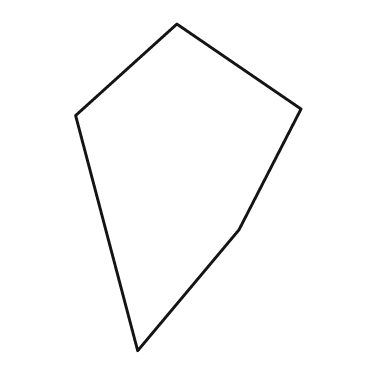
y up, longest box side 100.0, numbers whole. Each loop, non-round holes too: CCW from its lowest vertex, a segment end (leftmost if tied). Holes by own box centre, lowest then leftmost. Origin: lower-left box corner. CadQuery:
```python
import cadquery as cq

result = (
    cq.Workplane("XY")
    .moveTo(19.0, 0.0)
    .lineTo(50.0, 37.0)
    .lineTo(69.0, 74.0)
    .lineTo(31.0, 100.0)
    .lineTo(0.0, 72.0)
    .close()
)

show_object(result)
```